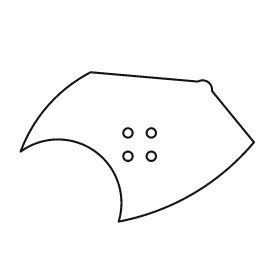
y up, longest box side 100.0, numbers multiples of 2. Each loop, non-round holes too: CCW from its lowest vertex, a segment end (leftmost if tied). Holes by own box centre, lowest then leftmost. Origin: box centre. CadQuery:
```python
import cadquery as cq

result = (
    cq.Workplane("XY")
    .moveTo(-8.0, -32.0)
    .threePointArc((24.0, -20.0), (50.0, 2.0))
    .lineTo(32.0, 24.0)
    .threePointArc((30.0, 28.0), (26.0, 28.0))
    .lineTo(-20.0, 32.0)
    .threePointArc((-38.0, 18.0), (-50.0, -2.0))
    .threePointArc((-18.0, -2.0), (-8.0, -32.0))
    .close()
    .moveTo(-4.0, -4.0)
    .circle(2.0)
    .moveTo(6.0, -4.0)
    .circle(2.0)
    .moveTo(-4.0, 6.0)
    .circle(2.0)
    .moveTo(6.0, 6.0)
    .circle(2.0)
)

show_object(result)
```